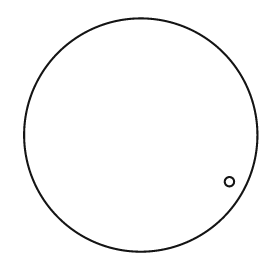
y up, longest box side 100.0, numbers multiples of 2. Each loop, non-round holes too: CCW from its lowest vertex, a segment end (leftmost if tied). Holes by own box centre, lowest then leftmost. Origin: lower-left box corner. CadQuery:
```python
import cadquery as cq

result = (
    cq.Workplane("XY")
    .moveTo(50.0, 50.0)
    .circle(50.0)
    .moveTo(88.0, 30.0)
    .circle(2.0)
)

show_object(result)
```